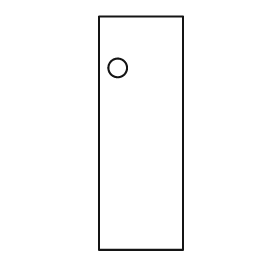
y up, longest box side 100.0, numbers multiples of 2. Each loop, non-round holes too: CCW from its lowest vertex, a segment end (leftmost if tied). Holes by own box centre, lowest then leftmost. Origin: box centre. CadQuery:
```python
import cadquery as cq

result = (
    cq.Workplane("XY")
    .moveTo(-18.0, -50.0)
    .lineTo(18.0, -50.0)
    .lineTo(18.0, 50.0)
    .lineTo(-18.0, 50.0)
    .close()
    .moveTo(-10.0, 28.0)
    .circle(4.0)
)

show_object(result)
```